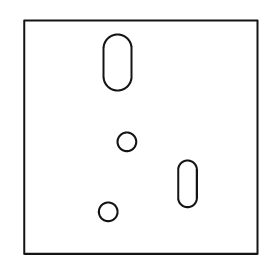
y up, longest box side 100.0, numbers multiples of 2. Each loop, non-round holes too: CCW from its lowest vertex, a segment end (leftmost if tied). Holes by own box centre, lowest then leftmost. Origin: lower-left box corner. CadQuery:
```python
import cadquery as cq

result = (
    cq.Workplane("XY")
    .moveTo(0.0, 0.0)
    .lineTo(100.0, 0.0)
    .lineTo(100.0, 100.0)
    .lineTo(0.0, 100.0)
    .close()
    .moveTo(36.0, 18.0)
    .circle(4.0)
    .moveTo(66.0, 24.0)
    .threePointArc((70.0, 20.0), (74.0, 24.0))
    .lineTo(74.0, 36.0)
    .threePointArc((70.0, 40.0), (66.0, 36.0))
    .close()
    .moveTo(44.0, 48.0)
    .circle(4.0)
    .moveTo(34.0, 76.0)
    .threePointArc((40.0, 70.0), (46.0, 76.0))
    .lineTo(46.0, 88.0)
    .threePointArc((40.0, 94.0), (34.0, 88.0))
    .close()
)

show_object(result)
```